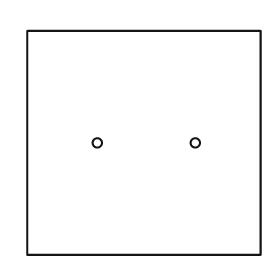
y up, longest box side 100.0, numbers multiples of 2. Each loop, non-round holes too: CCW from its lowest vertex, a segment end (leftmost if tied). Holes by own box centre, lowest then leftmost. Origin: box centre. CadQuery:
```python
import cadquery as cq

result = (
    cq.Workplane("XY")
    .moveTo(-50.0, -48.0)
    .lineTo(50.0, -48.0)
    .lineTo(50.0, 48.0)
    .lineTo(-50.0, 48.0)
    .close()
    .moveTo(-20.0, 0.0)
    .circle(2.0)
    .moveTo(22.0, 0.0)
    .circle(2.0)
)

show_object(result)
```